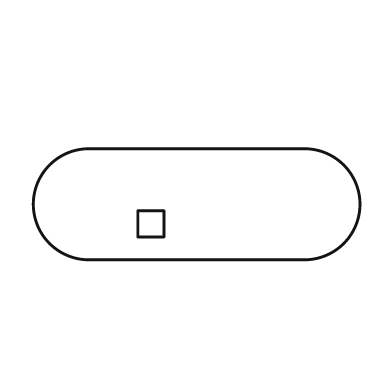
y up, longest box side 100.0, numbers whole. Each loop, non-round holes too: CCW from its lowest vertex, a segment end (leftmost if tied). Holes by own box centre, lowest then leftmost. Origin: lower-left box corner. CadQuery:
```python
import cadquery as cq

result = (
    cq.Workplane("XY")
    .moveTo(17.0, 0.0)
    .lineTo(83.0, 0.0)
    .threePointArc((100.0, 17.0), (83.0, 34.0))
    .lineTo(17.0, 34.0)
    .threePointArc((0.0, 17.0), (17.0, 0.0))
    .close()
    .moveTo(32.0, 7.0)
    .lineTo(40.0, 7.0)
    .lineTo(40.0, 15.0)
    .lineTo(32.0, 15.0)
    .close()
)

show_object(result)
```